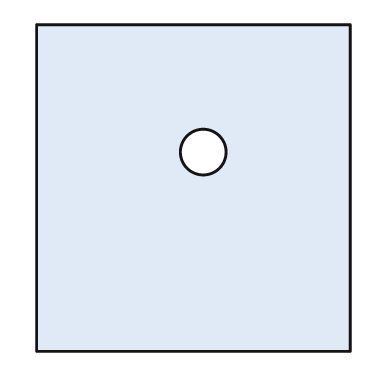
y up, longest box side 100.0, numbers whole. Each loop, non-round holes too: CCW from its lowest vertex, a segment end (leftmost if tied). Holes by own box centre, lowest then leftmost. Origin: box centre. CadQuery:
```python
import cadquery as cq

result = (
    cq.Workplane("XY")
    .moveTo(-48.0, -50.0)
    .lineTo(48.0, -50.0)
    .lineTo(48.0, 50.0)
    .lineTo(-48.0, 50.0)
    .close()
    .moveTo(3.0, 11.0)
    .circle(7.0)
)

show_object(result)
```